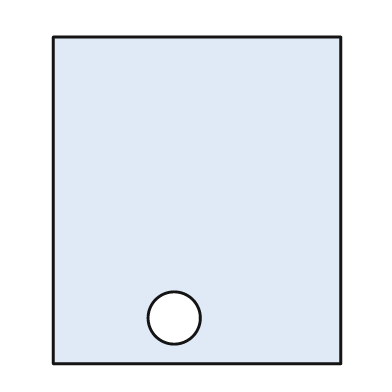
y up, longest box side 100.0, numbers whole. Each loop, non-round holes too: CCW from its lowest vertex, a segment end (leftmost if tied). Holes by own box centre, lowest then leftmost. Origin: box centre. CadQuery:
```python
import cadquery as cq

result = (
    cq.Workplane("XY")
    .moveTo(-44.0, -50.0)
    .lineTo(44.0, -50.0)
    .lineTo(44.0, 50.0)
    .lineTo(-44.0, 50.0)
    .close()
    .moveTo(-7.0, -36.0)
    .circle(8.0)
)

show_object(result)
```